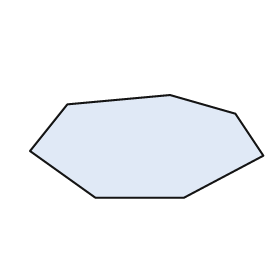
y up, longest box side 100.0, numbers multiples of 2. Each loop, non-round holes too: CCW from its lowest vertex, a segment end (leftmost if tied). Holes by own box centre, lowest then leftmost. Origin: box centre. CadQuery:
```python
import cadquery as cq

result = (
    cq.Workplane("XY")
    .moveTo(-22.0, -22.0)
    .lineTo(16.0, -22.0)
    .lineTo(50.0, -4.0)
    .lineTo(38.0, 14.0)
    .lineTo(10.0, 22.0)
    .lineTo(-34.0, 18.0)
    .lineTo(-50.0, -2.0)
    .close()
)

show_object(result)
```